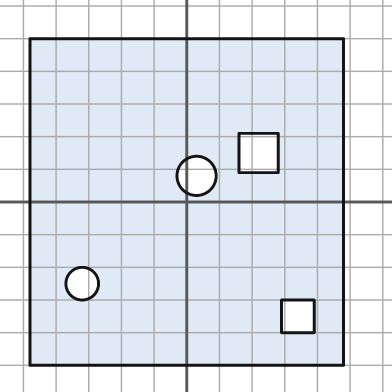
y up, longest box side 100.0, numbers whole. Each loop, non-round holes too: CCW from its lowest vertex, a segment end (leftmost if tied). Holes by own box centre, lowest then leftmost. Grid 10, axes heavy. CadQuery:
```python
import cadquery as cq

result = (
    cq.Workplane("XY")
    .moveTo(-48.0, -50.0)
    .lineTo(48.0, -50.0)
    .lineTo(48.0, 50.0)
    .lineTo(-48.0, 50.0)
    .close()
    .moveTo(29.0, -40.0)
    .lineTo(39.0, -40.0)
    .lineTo(39.0, -30.0)
    .lineTo(29.0, -30.0)
    .close()
    .moveTo(-32.0, -25.0)
    .circle(5.0)
    .moveTo(3.0, 8.0)
    .circle(6.0)
    .moveTo(16.0, 9.0)
    .lineTo(28.0, 9.0)
    .lineTo(28.0, 21.0)
    .lineTo(16.0, 21.0)
    .close()
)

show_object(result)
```